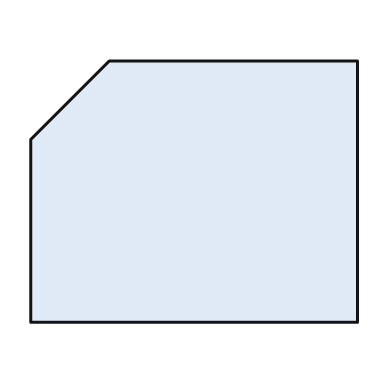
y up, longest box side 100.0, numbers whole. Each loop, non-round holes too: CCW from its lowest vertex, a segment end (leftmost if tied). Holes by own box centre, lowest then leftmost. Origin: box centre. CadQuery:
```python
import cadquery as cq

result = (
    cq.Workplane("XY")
    .moveTo(-50.0, -40.0)
    .lineTo(50.0, -40.0)
    .lineTo(50.0, 40.0)
    .lineTo(-26.0, 40.0)
    .lineTo(-50.0, 16.0)
    .close()
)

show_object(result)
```